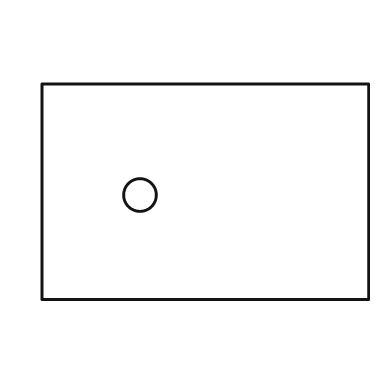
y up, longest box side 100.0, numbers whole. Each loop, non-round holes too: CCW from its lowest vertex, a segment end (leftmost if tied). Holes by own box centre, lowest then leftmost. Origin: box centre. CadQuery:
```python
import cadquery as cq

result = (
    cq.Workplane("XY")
    .moveTo(-50.0, -33.0)
    .lineTo(50.0, -33.0)
    .lineTo(50.0, 33.0)
    .lineTo(-50.0, 33.0)
    .close()
    .moveTo(-20.0, -1.0)
    .circle(5.0)
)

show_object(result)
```